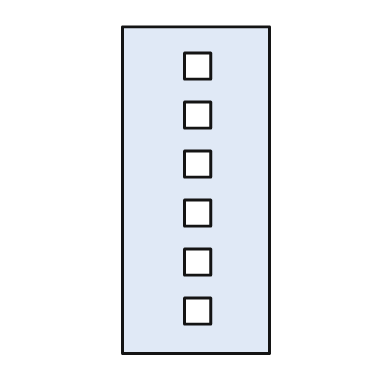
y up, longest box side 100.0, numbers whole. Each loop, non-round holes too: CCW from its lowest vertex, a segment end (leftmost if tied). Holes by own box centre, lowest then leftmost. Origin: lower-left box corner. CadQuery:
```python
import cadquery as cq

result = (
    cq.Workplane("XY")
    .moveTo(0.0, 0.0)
    .lineTo(45.0, 0.0)
    .lineTo(45.0, 100.0)
    .lineTo(0.0, 100.0)
    .close()
    .moveTo(19.0, 9.0)
    .lineTo(27.0, 9.0)
    .lineTo(27.0, 17.0)
    .lineTo(19.0, 17.0)
    .close()
    .moveTo(19.0, 24.0)
    .lineTo(27.0, 24.0)
    .lineTo(27.0, 32.0)
    .lineTo(19.0, 32.0)
    .close()
    .moveTo(19.0, 39.0)
    .lineTo(27.0, 39.0)
    .lineTo(27.0, 47.0)
    .lineTo(19.0, 47.0)
    .close()
    .moveTo(19.0, 54.0)
    .lineTo(27.0, 54.0)
    .lineTo(27.0, 62.0)
    .lineTo(19.0, 62.0)
    .close()
    .moveTo(19.0, 69.0)
    .lineTo(27.0, 69.0)
    .lineTo(27.0, 77.0)
    .lineTo(19.0, 77.0)
    .close()
    .moveTo(19.0, 84.0)
    .lineTo(27.0, 84.0)
    .lineTo(27.0, 92.0)
    .lineTo(19.0, 92.0)
    .close()
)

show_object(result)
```